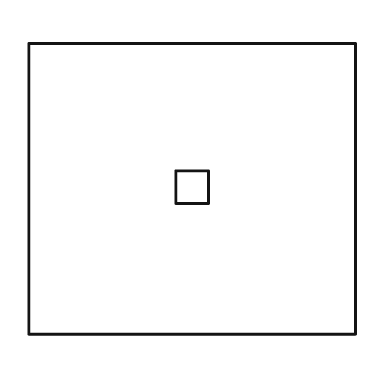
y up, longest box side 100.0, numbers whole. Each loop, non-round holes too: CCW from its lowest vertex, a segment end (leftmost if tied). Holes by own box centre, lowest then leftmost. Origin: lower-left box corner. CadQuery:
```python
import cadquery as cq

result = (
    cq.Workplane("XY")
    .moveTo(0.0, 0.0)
    .lineTo(100.0, 0.0)
    .lineTo(100.0, 89.0)
    .lineTo(0.0, 89.0)
    .close()
    .moveTo(45.0, 40.0)
    .lineTo(55.0, 40.0)
    .lineTo(55.0, 50.0)
    .lineTo(45.0, 50.0)
    .close()
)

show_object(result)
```